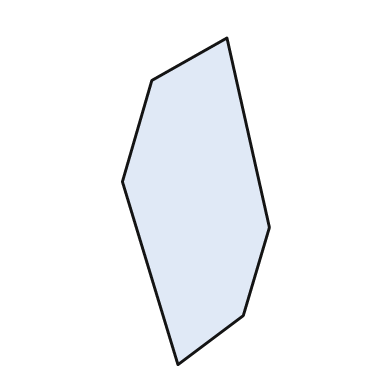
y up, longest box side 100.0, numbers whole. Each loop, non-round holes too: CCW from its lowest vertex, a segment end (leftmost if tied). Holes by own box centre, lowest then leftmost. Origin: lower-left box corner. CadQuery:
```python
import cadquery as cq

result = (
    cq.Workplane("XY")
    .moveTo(17.0, 0.0)
    .lineTo(37.0, 15.0)
    .lineTo(45.0, 42.0)
    .lineTo(32.0, 100.0)
    .lineTo(9.0, 87.0)
    .lineTo(0.0, 56.0)
    .close()
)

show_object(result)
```